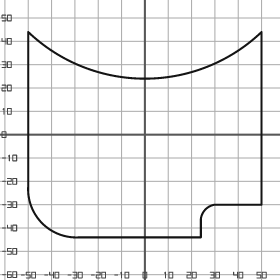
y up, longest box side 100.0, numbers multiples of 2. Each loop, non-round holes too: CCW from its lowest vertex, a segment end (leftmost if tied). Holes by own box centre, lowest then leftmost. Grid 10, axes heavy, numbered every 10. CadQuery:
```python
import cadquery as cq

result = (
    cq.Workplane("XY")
    .moveTo(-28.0, -44.0)
    .lineTo(24.0, -44.0)
    .lineTo(24.0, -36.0)
    .threePointArc((26.0, -32.0), (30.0, -30.0))
    .lineTo(50.0, -30.0)
    .lineTo(50.0, 44.0)
    .threePointArc((0.0, 24.0), (-50.0, 44.0))
    .lineTo(-50.0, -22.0)
    .threePointArc((-44.0, -38.0), (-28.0, -44.0))
    .close()
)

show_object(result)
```